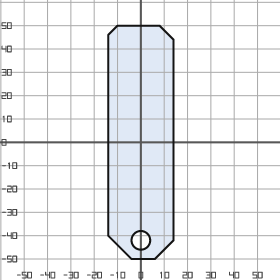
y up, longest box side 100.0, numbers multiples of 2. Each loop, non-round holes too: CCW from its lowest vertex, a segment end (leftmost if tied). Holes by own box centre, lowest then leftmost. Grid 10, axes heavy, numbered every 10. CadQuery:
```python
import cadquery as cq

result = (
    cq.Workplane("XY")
    .moveTo(-4.0, -50.0)
    .lineTo(6.0, -50.0)
    .lineTo(14.0, -42.0)
    .lineTo(14.0, 44.0)
    .lineTo(8.0, 50.0)
    .lineTo(-10.0, 50.0)
    .lineTo(-14.0, 46.0)
    .lineTo(-14.0, -40.0)
    .close()
    .moveTo(0.0, -42.0)
    .circle(4.0)
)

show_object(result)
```